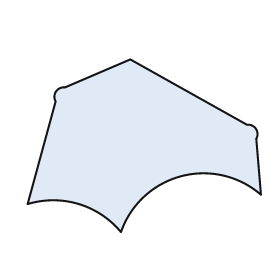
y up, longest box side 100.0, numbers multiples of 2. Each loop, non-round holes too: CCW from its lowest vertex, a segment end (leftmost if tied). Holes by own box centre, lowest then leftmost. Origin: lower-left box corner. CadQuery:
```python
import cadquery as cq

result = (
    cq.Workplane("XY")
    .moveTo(40.0, 0.0)
    .threePointArc((66.0, 24.0), (100.0, 16.0))
    .lineTo(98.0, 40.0)
    .threePointArc((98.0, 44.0), (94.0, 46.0))
    .lineTo(44.0, 74.0)
    .lineTo(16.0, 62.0)
    .threePointArc((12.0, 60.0), (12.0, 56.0))
    .lineTo(0.0, 12.0)
    .threePointArc((22.0, 12.0), (40.0, 0.0))
    .close()
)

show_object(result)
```